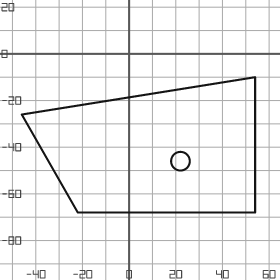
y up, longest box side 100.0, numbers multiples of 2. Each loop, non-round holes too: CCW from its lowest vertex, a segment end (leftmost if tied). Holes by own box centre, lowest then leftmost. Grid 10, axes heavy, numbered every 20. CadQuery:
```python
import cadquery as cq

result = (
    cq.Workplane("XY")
    .moveTo(-22.0, -68.0)
    .lineTo(54.0, -68.0)
    .lineTo(54.0, -10.0)
    .lineTo(-46.0, -26.0)
    .close()
    .moveTo(22.0, -46.0)
    .circle(4.0)
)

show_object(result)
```